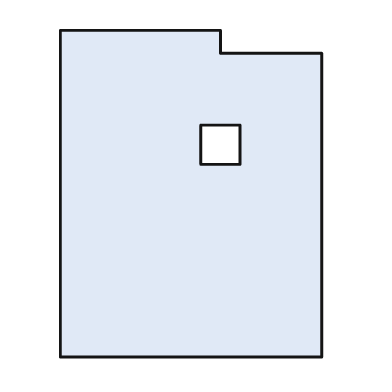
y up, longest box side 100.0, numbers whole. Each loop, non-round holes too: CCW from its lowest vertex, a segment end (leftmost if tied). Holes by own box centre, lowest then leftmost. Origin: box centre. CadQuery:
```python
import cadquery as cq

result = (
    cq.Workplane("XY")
    .moveTo(-40.0, -50.0)
    .lineTo(40.0, -50.0)
    .lineTo(40.0, 43.0)
    .lineTo(9.0, 43.0)
    .lineTo(9.0, 50.0)
    .lineTo(-40.0, 50.0)
    .close()
    .moveTo(3.0, 9.0)
    .lineTo(15.0, 9.0)
    .lineTo(15.0, 21.0)
    .lineTo(3.0, 21.0)
    .close()
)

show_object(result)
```